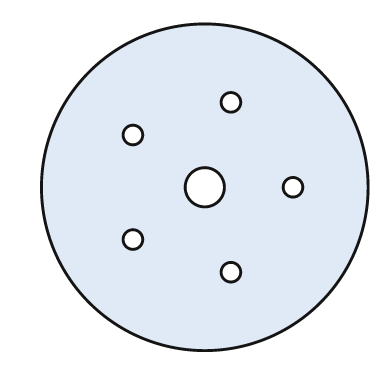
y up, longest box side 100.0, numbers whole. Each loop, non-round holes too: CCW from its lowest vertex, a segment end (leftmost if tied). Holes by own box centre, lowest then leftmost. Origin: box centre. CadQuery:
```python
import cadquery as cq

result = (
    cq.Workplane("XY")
    .moveTo(0.0, 0.0)
    .circle(50.0)
    .moveTo(8.0, -26.0)
    .circle(3.0)
    .moveTo(-22.0, -16.0)
    .circle(3.0)
    .moveTo(0.0, 0.0)
    .circle(6.0)
    .moveTo(27.0, 0.0)
    .circle(3.0)
    .moveTo(-22.0, 16.0)
    .circle(3.0)
    .moveTo(8.0, 26.0)
    .circle(3.0)
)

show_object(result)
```